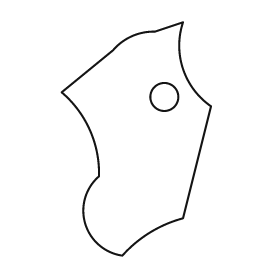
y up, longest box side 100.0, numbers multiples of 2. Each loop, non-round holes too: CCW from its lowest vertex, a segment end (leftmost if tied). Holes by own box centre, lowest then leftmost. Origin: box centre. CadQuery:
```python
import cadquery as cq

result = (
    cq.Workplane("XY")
    .moveTo(-6.0, -50.0)
    .threePointArc((6.0, -40.0), (20.0, -34.0))
    .lineTo(32.0, 14.0)
    .threePointArc((20.0, 30.0), (20.0, 50.0))
    .lineTo(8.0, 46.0)
    .threePointArc((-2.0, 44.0), (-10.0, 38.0))
    .lineTo(-32.0, 20.0)
    .threePointArc((-20.0, 4.0), (-16.0, -16.0))
    .threePointArc((-22.0, -36.0), (-6.0, -50.0))
    .close()
    .moveTo(12.0, 18.0)
    .circle(6.0)
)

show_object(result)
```